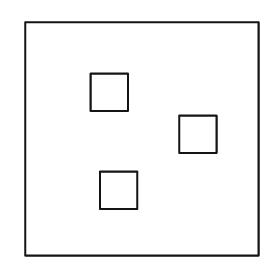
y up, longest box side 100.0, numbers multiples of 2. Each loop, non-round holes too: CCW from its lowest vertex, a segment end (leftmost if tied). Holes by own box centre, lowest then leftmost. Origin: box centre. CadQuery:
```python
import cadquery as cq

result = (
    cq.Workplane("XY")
    .moveTo(-50.0, -50.0)
    .lineTo(50.0, -50.0)
    .lineTo(50.0, 50.0)
    .lineTo(-50.0, 50.0)
    .close()
    .moveTo(-18.0, -30.0)
    .lineTo(-2.0, -30.0)
    .lineTo(-2.0, -14.0)
    .lineTo(-18.0, -14.0)
    .close()
    .moveTo(16.0, -6.0)
    .lineTo(32.0, -6.0)
    .lineTo(32.0, 10.0)
    .lineTo(16.0, 10.0)
    .close()
    .moveTo(-22.0, 12.0)
    .lineTo(-6.0, 12.0)
    .lineTo(-6.0, 28.0)
    .lineTo(-22.0, 28.0)
    .close()
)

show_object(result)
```